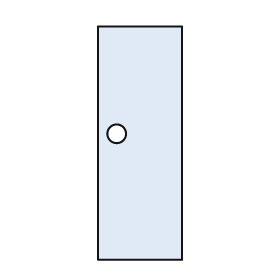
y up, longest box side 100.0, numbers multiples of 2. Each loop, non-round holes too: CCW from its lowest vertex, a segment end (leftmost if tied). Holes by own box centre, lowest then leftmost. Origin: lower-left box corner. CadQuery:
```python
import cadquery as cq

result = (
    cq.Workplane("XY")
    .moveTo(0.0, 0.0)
    .lineTo(36.0, 0.0)
    .lineTo(36.0, 100.0)
    .lineTo(0.0, 100.0)
    .close()
    .moveTo(8.0, 54.0)
    .circle(4.0)
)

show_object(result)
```